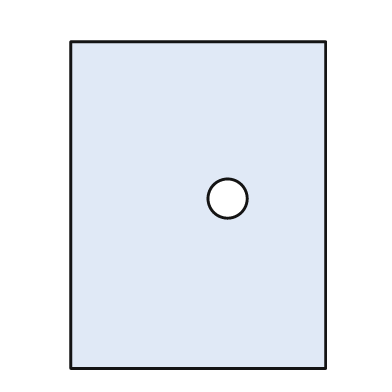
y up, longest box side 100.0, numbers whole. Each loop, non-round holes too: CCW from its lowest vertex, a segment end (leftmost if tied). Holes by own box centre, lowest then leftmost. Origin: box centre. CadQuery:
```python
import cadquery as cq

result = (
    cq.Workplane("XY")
    .moveTo(-39.0, -50.0)
    .lineTo(39.0, -50.0)
    .lineTo(39.0, 50.0)
    .lineTo(-39.0, 50.0)
    .close()
    .moveTo(9.0, 2.0)
    .circle(6.0)
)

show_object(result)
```